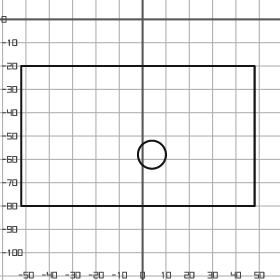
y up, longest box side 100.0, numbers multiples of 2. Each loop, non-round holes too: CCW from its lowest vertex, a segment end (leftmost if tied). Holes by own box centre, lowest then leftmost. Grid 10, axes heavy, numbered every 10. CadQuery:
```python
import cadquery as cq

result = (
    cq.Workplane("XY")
    .moveTo(-52.0, -80.0)
    .lineTo(48.0, -80.0)
    .lineTo(48.0, -20.0)
    .lineTo(-52.0, -20.0)
    .close()
    .moveTo(4.0, -58.0)
    .circle(6.0)
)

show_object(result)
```